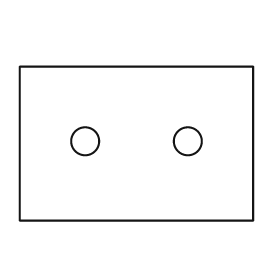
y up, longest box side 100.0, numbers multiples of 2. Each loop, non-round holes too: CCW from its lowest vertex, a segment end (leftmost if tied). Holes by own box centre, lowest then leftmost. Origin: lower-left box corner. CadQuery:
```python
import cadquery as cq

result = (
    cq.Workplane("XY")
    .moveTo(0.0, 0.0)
    .lineTo(100.0, 0.0)
    .lineTo(100.0, 66.0)
    .lineTo(0.0, 66.0)
    .close()
    .moveTo(28.0, 34.0)
    .circle(6.0)
    .moveTo(72.0, 34.0)
    .circle(6.0)
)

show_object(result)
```